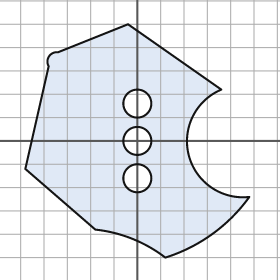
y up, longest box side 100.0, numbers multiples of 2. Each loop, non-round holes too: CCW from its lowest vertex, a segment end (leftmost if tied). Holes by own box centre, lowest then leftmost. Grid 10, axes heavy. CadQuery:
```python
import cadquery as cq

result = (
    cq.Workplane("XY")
    .moveTo(12.0, -50.0)
    .threePointArc((32.0, -40.0), (48.0, -24.0))
    .threePointArc((22.0, -6.0), (36.0, 22.0))
    .lineTo(-4.0, 50.0)
    .lineTo(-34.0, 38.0)
    .threePointArc((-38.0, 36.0), (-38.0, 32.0))
    .lineTo(-48.0, -12.0)
    .lineTo(-18.0, -38.0)
    .threePointArc((-2.0, -42.0), (12.0, -50.0))
    .close()
    .moveTo(0.0, -16.0)
    .circle(6.0)
    .moveTo(0.0, 0.0)
    .circle(6.0)
    .moveTo(0.0, 16.0)
    .circle(6.0)
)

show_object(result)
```